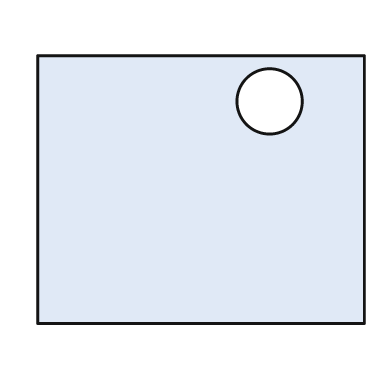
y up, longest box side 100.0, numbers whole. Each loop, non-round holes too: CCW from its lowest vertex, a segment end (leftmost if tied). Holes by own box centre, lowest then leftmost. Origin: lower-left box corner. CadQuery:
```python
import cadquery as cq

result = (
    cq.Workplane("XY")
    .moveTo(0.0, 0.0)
    .lineTo(100.0, 0.0)
    .lineTo(100.0, 82.0)
    .lineTo(0.0, 82.0)
    .close()
    .moveTo(71.0, 68.0)
    .circle(10.0)
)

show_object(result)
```